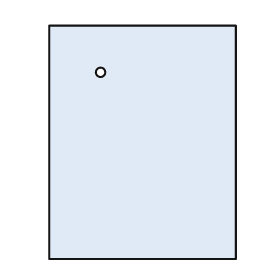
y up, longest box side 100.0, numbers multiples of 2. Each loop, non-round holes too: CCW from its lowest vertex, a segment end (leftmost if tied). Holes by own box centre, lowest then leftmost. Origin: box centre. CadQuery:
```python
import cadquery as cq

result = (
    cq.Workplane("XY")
    .moveTo(-40.0, -50.0)
    .lineTo(40.0, -50.0)
    .lineTo(40.0, 50.0)
    .lineTo(-40.0, 50.0)
    .close()
    .moveTo(-18.0, 30.0)
    .circle(2.0)
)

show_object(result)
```